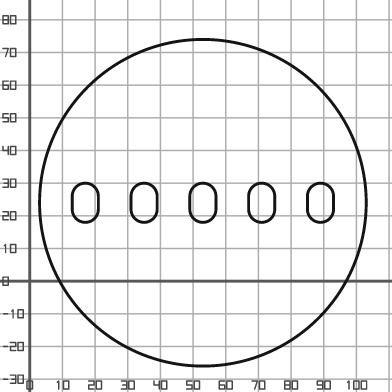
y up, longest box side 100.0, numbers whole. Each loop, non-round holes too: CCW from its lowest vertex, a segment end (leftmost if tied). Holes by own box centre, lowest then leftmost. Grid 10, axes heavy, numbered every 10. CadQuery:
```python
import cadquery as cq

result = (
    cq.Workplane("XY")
    .moveTo(53.0, 24.0)
    .circle(50.0)
    .moveTo(13.0, 22.0)
    .threePointArc((17.0, 18.0), (21.0, 22.0))
    .lineTo(21.0, 26.0)
    .threePointArc((17.0, 30.0), (13.0, 26.0))
    .close()
    .moveTo(31.0, 22.0)
    .threePointArc((35.0, 18.0), (39.0, 22.0))
    .lineTo(39.0, 26.0)
    .threePointArc((35.0, 30.0), (31.0, 26.0))
    .close()
    .moveTo(49.0, 22.0)
    .threePointArc((53.0, 18.0), (57.0, 22.0))
    .lineTo(57.0, 26.0)
    .threePointArc((53.0, 30.0), (49.0, 26.0))
    .close()
    .moveTo(67.0, 22.0)
    .threePointArc((71.0, 18.0), (75.0, 22.0))
    .lineTo(75.0, 26.0)
    .threePointArc((71.0, 30.0), (67.0, 26.0))
    .close()
    .moveTo(85.0, 22.0)
    .threePointArc((89.0, 18.0), (93.0, 22.0))
    .lineTo(93.0, 26.0)
    .threePointArc((89.0, 30.0), (85.0, 26.0))
    .close()
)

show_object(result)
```